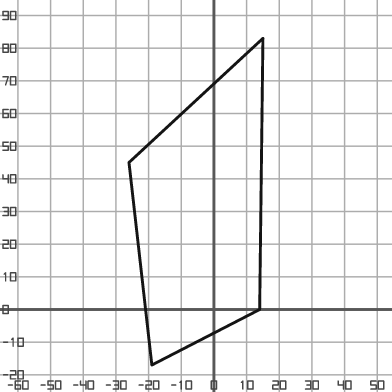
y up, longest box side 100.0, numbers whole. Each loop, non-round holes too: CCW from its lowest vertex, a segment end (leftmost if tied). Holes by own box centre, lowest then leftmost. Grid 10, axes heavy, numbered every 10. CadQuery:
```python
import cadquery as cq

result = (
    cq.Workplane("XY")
    .moveTo(-19.0, -17.0)
    .lineTo(14.0, 0.0)
    .lineTo(15.0, 83.0)
    .lineTo(-26.0, 45.0)
    .close()
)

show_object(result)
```